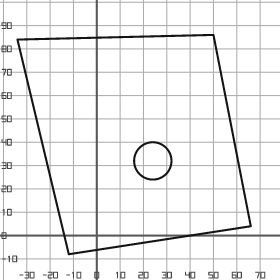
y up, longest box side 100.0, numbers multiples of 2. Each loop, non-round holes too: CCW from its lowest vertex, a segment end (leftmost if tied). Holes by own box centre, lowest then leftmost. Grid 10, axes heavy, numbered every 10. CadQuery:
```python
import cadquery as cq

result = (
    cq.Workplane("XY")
    .moveTo(-12.0, -8.0)
    .lineTo(66.0, 4.0)
    .lineTo(50.0, 86.0)
    .lineTo(-34.0, 84.0)
    .close()
    .moveTo(24.0, 32.0)
    .circle(8.0)
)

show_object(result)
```